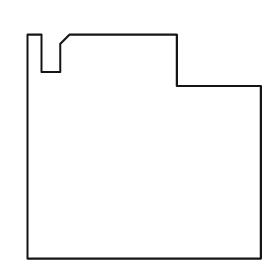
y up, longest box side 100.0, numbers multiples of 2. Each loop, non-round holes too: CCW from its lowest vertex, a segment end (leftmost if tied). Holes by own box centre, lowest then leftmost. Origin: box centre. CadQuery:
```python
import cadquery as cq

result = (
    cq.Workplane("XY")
    .moveTo(-50.0, -48.0)
    .lineTo(50.0, -48.0)
    .lineTo(50.0, 26.0)
    .lineTo(14.0, 26.0)
    .lineTo(14.0, 48.0)
    .lineTo(-32.0, 48.0)
    .lineTo(-36.0, 44.0)
    .lineTo(-36.0, 32.0)
    .lineTo(-44.0, 32.0)
    .lineTo(-44.0, 48.0)
    .lineTo(-50.0, 48.0)
    .close()
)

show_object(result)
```